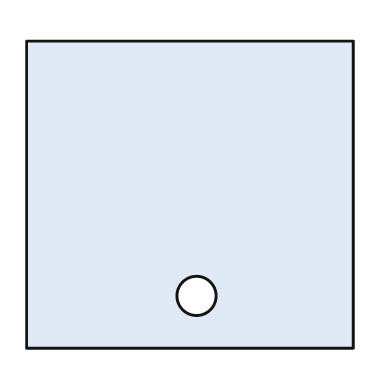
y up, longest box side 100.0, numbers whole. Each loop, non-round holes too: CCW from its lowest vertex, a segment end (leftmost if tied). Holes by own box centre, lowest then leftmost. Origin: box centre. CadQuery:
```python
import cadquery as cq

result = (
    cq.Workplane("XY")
    .moveTo(-50.0, -47.0)
    .lineTo(50.0, -47.0)
    .lineTo(50.0, 47.0)
    .lineTo(-50.0, 47.0)
    .close()
    .moveTo(2.0, -31.0)
    .circle(6.0)
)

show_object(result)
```